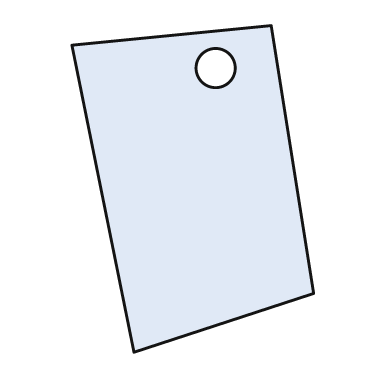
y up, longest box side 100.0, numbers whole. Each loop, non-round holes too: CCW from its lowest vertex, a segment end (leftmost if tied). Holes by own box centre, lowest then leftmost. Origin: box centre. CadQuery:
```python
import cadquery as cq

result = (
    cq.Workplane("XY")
    .moveTo(-18.0, -50.0)
    .lineTo(37.0, -32.0)
    .lineTo(24.0, 50.0)
    .lineTo(-37.0, 44.0)
    .close()
    .moveTo(7.0, 37.0)
    .circle(6.0)
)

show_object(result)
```